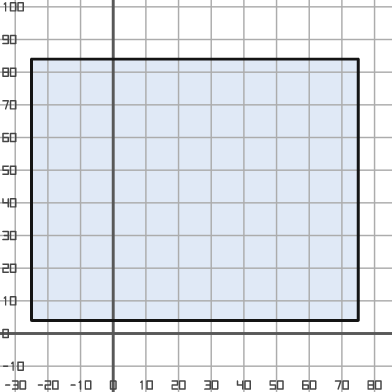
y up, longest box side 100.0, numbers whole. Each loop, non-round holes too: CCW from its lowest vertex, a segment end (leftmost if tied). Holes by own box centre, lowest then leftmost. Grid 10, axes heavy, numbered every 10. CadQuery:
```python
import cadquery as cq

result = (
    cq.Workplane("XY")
    .moveTo(-25.0, 4.0)
    .lineTo(75.0, 4.0)
    .lineTo(75.0, 84.0)
    .lineTo(-25.0, 84.0)
    .close()
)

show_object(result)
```